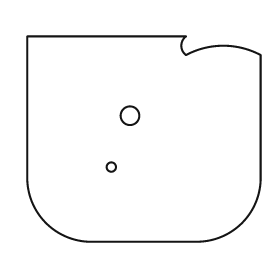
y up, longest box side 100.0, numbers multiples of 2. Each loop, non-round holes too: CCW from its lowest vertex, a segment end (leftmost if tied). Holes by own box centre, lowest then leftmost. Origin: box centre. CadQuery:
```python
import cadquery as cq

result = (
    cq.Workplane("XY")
    .moveTo(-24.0, -44.0)
    .lineTo(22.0, -44.0)
    .threePointArc((42.0, -36.0), (50.0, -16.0))
    .lineTo(50.0, 36.0)
    .threePointArc((34.0, 40.0), (18.0, 36.0))
    .threePointArc((16.0, 40.0), (18.0, 44.0))
    .lineTo(-50.0, 44.0)
    .lineTo(-50.0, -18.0)
    .threePointArc((-42.0, -36.0), (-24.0, -44.0))
    .close()
    .moveTo(-14.0, -12.0)
    .circle(2.0)
    .moveTo(-6.0, 10.0)
    .circle(4.0)
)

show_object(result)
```